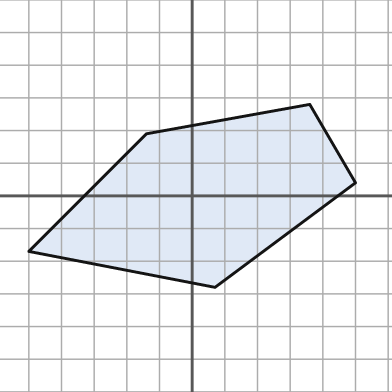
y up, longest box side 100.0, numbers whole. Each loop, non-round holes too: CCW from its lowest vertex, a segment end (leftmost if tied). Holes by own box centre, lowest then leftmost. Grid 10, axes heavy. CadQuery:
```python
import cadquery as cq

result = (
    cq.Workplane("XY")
    .moveTo(7.0, -28.0)
    .lineTo(50.0, 4.0)
    .lineTo(36.0, 28.0)
    .lineTo(-14.0, 19.0)
    .lineTo(-50.0, -17.0)
    .close()
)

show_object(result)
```